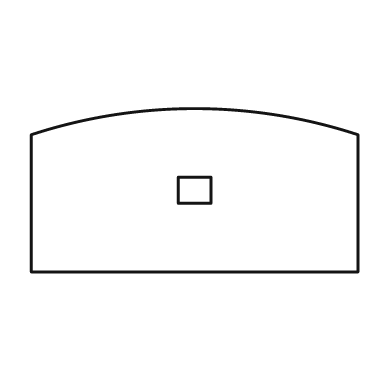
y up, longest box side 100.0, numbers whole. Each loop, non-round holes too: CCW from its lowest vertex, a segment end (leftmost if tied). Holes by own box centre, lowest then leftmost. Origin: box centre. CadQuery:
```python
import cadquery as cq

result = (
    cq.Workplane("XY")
    .moveTo(-50.0, -25.0)
    .lineTo(50.0, -25.0)
    .lineTo(50.0, 17.0)
    .threePointArc((0.0, 25.0), (-50.0, 17.0))
    .close()
    .moveTo(-5.0, -4.0)
    .lineTo(5.0, -4.0)
    .lineTo(5.0, 4.0)
    .lineTo(-5.0, 4.0)
    .close()
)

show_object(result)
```